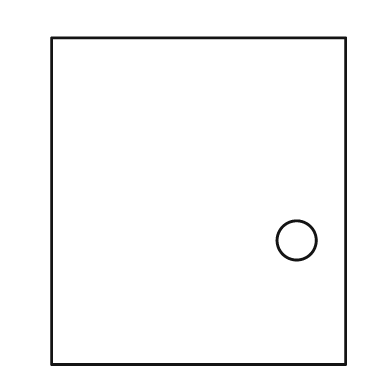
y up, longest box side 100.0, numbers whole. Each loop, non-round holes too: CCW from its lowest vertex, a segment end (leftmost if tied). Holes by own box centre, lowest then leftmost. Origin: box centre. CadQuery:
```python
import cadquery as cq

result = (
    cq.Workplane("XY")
    .moveTo(-45.0, -50.0)
    .lineTo(45.0, -50.0)
    .lineTo(45.0, 50.0)
    .lineTo(-45.0, 50.0)
    .close()
    .moveTo(30.0, -12.0)
    .circle(6.0)
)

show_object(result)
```